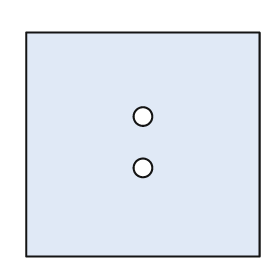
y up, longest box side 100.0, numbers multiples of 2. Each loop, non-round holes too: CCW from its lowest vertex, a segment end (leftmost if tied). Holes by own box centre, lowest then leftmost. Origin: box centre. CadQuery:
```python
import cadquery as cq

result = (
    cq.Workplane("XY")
    .moveTo(-50.0, -48.0)
    .lineTo(50.0, -48.0)
    .lineTo(50.0, 48.0)
    .lineTo(-50.0, 48.0)
    .close()
    .moveTo(0.0, -10.0)
    .circle(4.0)
    .moveTo(0.0, 12.0)
    .circle(4.0)
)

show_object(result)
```